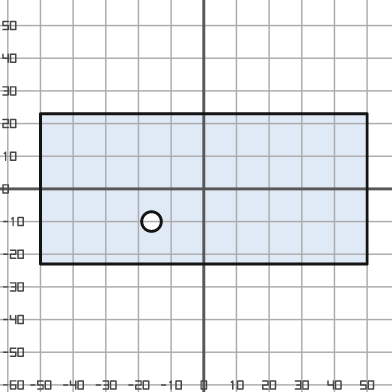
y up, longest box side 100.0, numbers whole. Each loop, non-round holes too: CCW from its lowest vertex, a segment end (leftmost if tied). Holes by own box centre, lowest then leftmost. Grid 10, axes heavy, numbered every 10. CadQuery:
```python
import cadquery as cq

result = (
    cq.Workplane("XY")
    .moveTo(-50.0, -23.0)
    .lineTo(50.0, -23.0)
    .lineTo(50.0, 23.0)
    .lineTo(-50.0, 23.0)
    .close()
    .moveTo(-16.0, -10.0)
    .circle(3.0)
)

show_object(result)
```